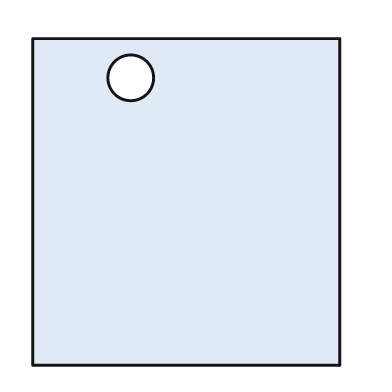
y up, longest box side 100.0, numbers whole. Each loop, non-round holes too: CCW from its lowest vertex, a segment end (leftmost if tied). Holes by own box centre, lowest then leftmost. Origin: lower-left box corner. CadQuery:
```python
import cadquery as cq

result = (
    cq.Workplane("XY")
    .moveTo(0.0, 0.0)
    .lineTo(94.0, 0.0)
    .lineTo(94.0, 100.0)
    .lineTo(0.0, 100.0)
    .close()
    .moveTo(30.0, 88.0)
    .circle(7.0)
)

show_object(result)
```